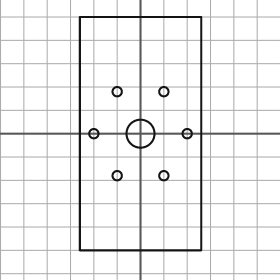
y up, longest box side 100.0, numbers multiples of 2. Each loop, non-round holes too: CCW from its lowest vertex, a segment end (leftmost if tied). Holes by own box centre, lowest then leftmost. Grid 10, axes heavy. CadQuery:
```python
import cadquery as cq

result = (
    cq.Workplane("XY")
    .moveTo(-26.0, -50.0)
    .lineTo(26.0, -50.0)
    .lineTo(26.0, 50.0)
    .lineTo(-26.0, 50.0)
    .close()
    .moveTo(-10.0, -18.0)
    .circle(2.0)
    .moveTo(10.0, -18.0)
    .circle(2.0)
    .moveTo(-20.0, 0.0)
    .circle(2.0)
    .moveTo(0.0, 0.0)
    .circle(6.0)
    .moveTo(20.0, 0.0)
    .circle(2.0)
    .moveTo(-10.0, 18.0)
    .circle(2.0)
    .moveTo(10.0, 18.0)
    .circle(2.0)
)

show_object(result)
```